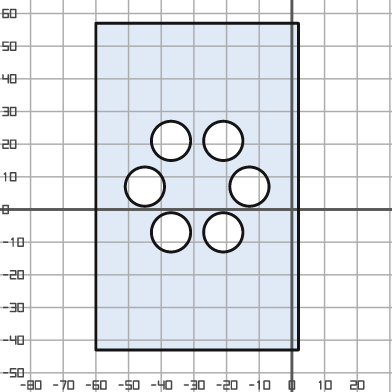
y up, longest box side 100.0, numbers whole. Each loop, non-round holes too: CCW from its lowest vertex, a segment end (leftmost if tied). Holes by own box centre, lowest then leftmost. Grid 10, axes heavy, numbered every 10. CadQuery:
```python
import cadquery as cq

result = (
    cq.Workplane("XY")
    .moveTo(-60.0, -43.0)
    .lineTo(2.0, -43.0)
    .lineTo(2.0, 57.0)
    .lineTo(-60.0, 57.0)
    .close()
    .moveTo(-37.0, -7.0)
    .circle(6.0)
    .moveTo(-21.0, -7.0)
    .circle(6.0)
    .moveTo(-45.0, 7.0)
    .circle(6.0)
    .moveTo(-13.0, 7.0)
    .circle(6.0)
    .moveTo(-37.0, 21.0)
    .circle(6.0)
    .moveTo(-21.0, 21.0)
    .circle(6.0)
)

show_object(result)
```